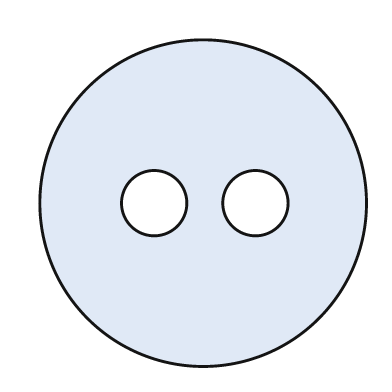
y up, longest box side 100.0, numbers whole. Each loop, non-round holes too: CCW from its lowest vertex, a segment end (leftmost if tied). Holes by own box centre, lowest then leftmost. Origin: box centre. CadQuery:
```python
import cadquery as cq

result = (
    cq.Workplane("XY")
    .moveTo(0.0, 0.0)
    .circle(50.0)
    .moveTo(-15.0, 0.0)
    .circle(10.0)
    .moveTo(16.0, 0.0)
    .circle(10.0)
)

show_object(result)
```